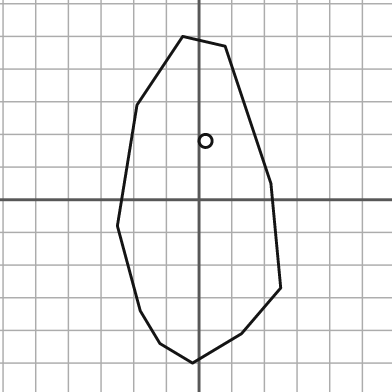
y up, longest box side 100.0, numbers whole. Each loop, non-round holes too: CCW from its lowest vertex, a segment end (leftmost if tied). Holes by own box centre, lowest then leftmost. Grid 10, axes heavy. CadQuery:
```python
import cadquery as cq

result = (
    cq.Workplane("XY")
    .moveTo(-2.0, -50.0)
    .lineTo(13.0, -41.0)
    .lineTo(25.0, -27.0)
    .lineTo(22.0, 5.0)
    .lineTo(8.0, 47.0)
    .lineTo(-5.0, 50.0)
    .lineTo(-19.0, 29.0)
    .lineTo(-25.0, -8.0)
    .lineTo(-18.0, -34.0)
    .lineTo(-12.0, -44.0)
    .close()
    .moveTo(2.0, 18.0)
    .circle(2.0)
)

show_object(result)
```